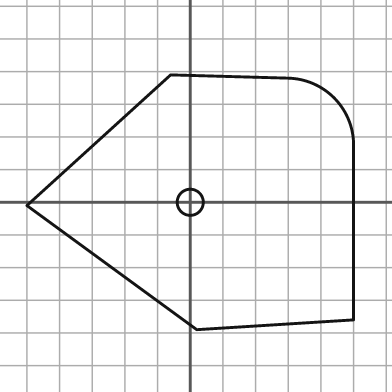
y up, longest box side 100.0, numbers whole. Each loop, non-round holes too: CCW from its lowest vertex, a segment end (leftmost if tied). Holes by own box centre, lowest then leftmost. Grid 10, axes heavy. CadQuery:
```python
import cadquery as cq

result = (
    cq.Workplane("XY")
    .moveTo(2.0, -39.0)
    .lineTo(50.0, -36.0)
    .lineTo(50.0, 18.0)
    .threePointArc((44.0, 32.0), (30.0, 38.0))
    .lineTo(-6.0, 39.0)
    .lineTo(-50.0, -1.0)
    .close()
    .moveTo(0.0, 0.0)
    .circle(4.0)
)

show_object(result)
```